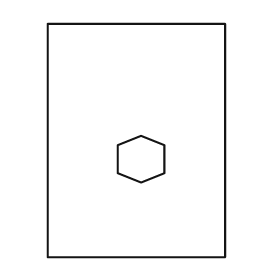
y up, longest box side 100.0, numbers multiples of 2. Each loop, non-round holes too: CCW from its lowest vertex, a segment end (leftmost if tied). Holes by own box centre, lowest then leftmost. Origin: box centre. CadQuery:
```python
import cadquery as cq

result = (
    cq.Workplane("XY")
    .moveTo(-38.0, -50.0)
    .lineTo(38.0, -50.0)
    .lineTo(38.0, 50.0)
    .lineTo(-38.0, 50.0)
    .close()
    .moveTo(2.0, -18.0)
    .lineTo(12.0, -14.0)
    .lineTo(12.0, -2.0)
    .lineTo(2.0, 2.0)
    .lineTo(-8.0, -2.0)
    .lineTo(-8.0, -14.0)
    .close()
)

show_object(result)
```